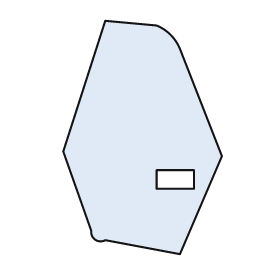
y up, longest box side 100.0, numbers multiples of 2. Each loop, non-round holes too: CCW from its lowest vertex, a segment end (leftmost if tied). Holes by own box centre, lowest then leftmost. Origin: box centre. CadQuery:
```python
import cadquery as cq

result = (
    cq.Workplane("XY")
    .moveTo(16.0, -50.0)
    .lineTo(34.0, -8.0)
    .lineTo(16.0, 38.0)
    .threePointArc((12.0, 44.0), (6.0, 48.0))
    .lineTo(-16.0, 50.0)
    .lineTo(-34.0, -6.0)
    .lineTo(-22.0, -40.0)
    .threePointArc((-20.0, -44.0), (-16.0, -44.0))
    .close()
    .moveTo(6.0, -22.0)
    .lineTo(22.0, -22.0)
    .lineTo(22.0, -14.0)
    .lineTo(6.0, -14.0)
    .close()
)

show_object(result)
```